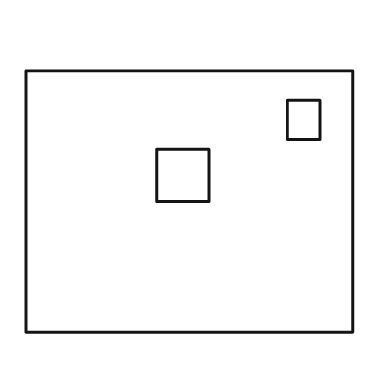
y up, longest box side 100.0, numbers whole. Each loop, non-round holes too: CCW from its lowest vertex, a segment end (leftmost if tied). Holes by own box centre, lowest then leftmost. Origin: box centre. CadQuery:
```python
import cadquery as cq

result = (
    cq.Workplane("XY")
    .moveTo(-50.0, -40.0)
    .lineTo(50.0, -40.0)
    .lineTo(50.0, 40.0)
    .lineTo(-50.0, 40.0)
    .close()
    .moveTo(-10.0, 0.0)
    .lineTo(6.0, 0.0)
    .lineTo(6.0, 16.0)
    .lineTo(-10.0, 16.0)
    .close()
    .moveTo(30.0, 19.0)
    .lineTo(40.0, 19.0)
    .lineTo(40.0, 31.0)
    .lineTo(30.0, 31.0)
    .close()
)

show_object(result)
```